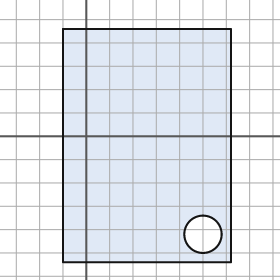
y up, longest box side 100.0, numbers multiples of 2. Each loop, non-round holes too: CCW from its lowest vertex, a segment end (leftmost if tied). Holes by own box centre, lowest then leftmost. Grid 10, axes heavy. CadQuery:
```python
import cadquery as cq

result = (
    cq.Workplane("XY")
    .moveTo(-10.0, -54.0)
    .lineTo(62.0, -54.0)
    .lineTo(62.0, 46.0)
    .lineTo(-10.0, 46.0)
    .close()
    .moveTo(50.0, -42.0)
    .circle(8.0)
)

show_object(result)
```